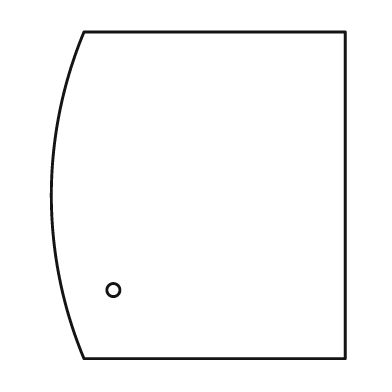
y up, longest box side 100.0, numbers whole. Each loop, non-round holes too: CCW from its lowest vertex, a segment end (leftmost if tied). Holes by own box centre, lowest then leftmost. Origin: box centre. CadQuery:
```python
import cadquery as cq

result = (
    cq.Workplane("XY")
    .moveTo(-35.0, -50.0)
    .lineTo(45.0, -50.0)
    .lineTo(45.0, 50.0)
    .lineTo(-35.0, 50.0)
    .threePointArc((-45.0, 0.0), (-35.0, -50.0))
    .close()
    .moveTo(-26.0, -29.0)
    .circle(2.0)
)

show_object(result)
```